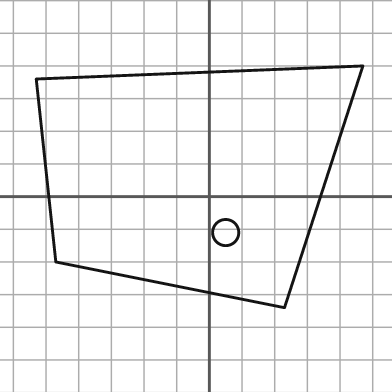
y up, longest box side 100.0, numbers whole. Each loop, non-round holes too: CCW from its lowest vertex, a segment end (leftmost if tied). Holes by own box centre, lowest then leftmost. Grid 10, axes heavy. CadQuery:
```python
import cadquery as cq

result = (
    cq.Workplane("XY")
    .moveTo(23.0, -34.0)
    .lineTo(47.0, 40.0)
    .lineTo(-53.0, 36.0)
    .lineTo(-47.0, -20.0)
    .close()
    .moveTo(5.0, -11.0)
    .circle(4.0)
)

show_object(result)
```